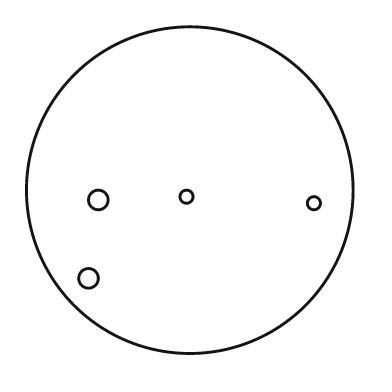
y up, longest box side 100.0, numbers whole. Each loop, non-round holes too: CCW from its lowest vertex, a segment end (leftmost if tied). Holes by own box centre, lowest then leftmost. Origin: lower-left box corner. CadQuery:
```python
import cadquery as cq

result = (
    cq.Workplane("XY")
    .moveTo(50.0, 50.0)
    .circle(50.0)
    .moveTo(19.0, 23.0)
    .circle(3.0)
    .moveTo(88.0, 46.0)
    .circle(2.0)
    .moveTo(22.0, 47.0)
    .circle(3.0)
    .moveTo(49.0, 48.0)
    .circle(2.0)
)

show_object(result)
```